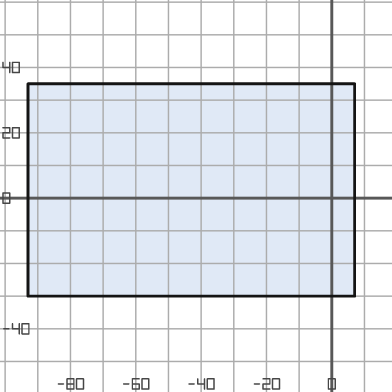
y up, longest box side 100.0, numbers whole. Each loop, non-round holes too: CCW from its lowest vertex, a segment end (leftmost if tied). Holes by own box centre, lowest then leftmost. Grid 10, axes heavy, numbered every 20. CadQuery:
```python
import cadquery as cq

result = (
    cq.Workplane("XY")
    .moveTo(-93.0, -30.0)
    .lineTo(7.0, -30.0)
    .lineTo(7.0, 35.0)
    .lineTo(-93.0, 35.0)
    .close()
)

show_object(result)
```